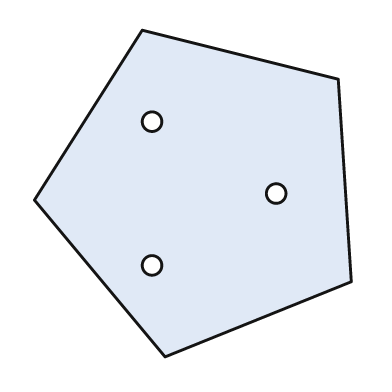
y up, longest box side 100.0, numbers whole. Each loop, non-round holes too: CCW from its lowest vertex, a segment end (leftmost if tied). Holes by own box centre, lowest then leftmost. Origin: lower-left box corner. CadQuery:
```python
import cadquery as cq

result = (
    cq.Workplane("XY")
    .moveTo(40.0, 0.0)
    .lineTo(97.0, 23.0)
    .lineTo(93.0, 85.0)
    .lineTo(33.0, 100.0)
    .lineTo(0.0, 48.0)
    .close()
    .moveTo(36.0, 28.0)
    .circle(3.0)
    .moveTo(74.0, 50.0)
    .circle(3.0)
    .moveTo(36.0, 72.0)
    .circle(3.0)
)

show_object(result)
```